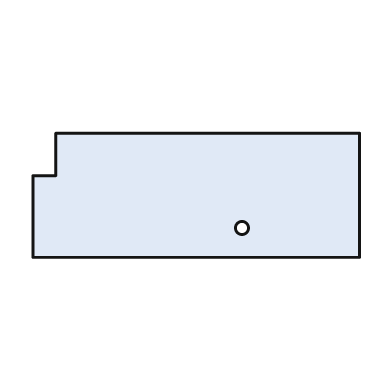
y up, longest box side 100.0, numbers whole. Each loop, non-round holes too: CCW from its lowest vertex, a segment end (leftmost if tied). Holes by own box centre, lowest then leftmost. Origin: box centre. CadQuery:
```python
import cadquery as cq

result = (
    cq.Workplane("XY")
    .moveTo(-50.0, -19.0)
    .lineTo(50.0, -19.0)
    .lineTo(50.0, 19.0)
    .lineTo(-43.0, 19.0)
    .lineTo(-43.0, 6.0)
    .lineTo(-50.0, 6.0)
    .close()
    .moveTo(14.0, -10.0)
    .circle(2.0)
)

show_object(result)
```